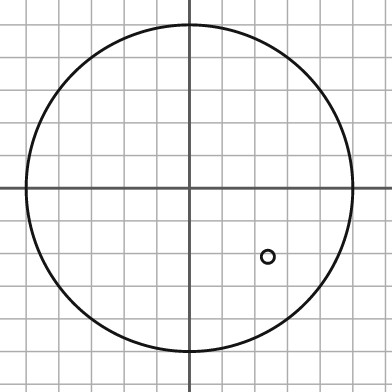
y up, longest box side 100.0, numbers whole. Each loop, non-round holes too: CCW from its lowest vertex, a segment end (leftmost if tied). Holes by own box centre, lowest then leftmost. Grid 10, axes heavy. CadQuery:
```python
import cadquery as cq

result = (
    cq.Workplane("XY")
    .moveTo(0.0, 0.0)
    .circle(50.0)
    .moveTo(24.0, -21.0)
    .circle(2.0)
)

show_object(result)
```